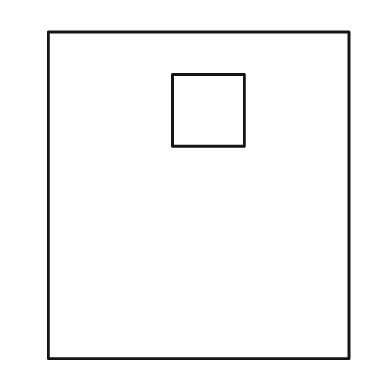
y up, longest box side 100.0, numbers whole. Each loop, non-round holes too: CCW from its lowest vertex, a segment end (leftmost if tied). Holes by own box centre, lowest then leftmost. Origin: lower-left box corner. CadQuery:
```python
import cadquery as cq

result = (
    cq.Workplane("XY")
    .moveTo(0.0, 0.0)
    .lineTo(92.0, 0.0)
    .lineTo(92.0, 100.0)
    .lineTo(0.0, 100.0)
    .close()
    .moveTo(38.0, 65.0)
    .lineTo(60.0, 65.0)
    .lineTo(60.0, 87.0)
    .lineTo(38.0, 87.0)
    .close()
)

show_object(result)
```